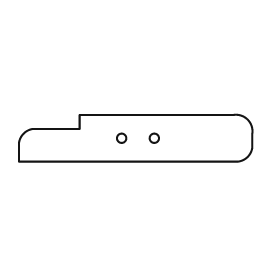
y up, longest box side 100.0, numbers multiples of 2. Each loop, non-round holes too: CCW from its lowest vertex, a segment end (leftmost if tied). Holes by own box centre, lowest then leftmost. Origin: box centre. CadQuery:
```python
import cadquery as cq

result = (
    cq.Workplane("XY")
    .moveTo(-50.0, -10.0)
    .lineTo(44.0, -10.0)
    .threePointArc((48.0, -8.0), (50.0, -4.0))
    .lineTo(50.0, 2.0)
    .threePointArc((48.0, 8.0), (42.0, 10.0))
    .lineTo(-24.0, 10.0)
    .lineTo(-24.0, 4.0)
    .lineTo(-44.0, 4.0)
    .threePointArc((-48.0, 2.0), (-50.0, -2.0))
    .close()
    .moveTo(-6.0, 0.0)
    .circle(2.0)
    .moveTo(8.0, 0.0)
    .circle(2.0)
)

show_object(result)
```